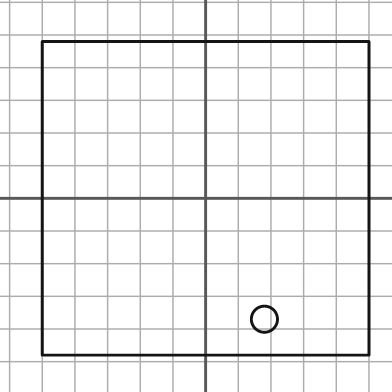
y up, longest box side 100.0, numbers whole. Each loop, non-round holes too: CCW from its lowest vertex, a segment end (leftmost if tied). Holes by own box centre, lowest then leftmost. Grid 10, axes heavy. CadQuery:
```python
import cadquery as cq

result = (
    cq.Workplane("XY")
    .moveTo(-50.0, -48.0)
    .lineTo(50.0, -48.0)
    .lineTo(50.0, 48.0)
    .lineTo(-50.0, 48.0)
    .close()
    .moveTo(18.0, -37.0)
    .circle(4.0)
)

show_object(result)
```